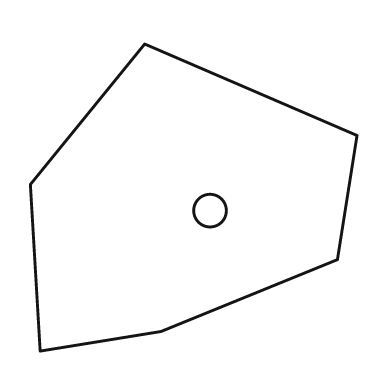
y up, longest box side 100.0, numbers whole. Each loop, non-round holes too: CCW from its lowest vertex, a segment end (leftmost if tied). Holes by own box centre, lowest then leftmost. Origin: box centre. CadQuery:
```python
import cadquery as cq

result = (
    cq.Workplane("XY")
    .moveTo(-47.0, -47.0)
    .lineTo(-10.0, -41.0)
    .lineTo(44.0, -19.0)
    .lineTo(50.0, 19.0)
    .lineTo(-15.0, 47.0)
    .lineTo(-50.0, 4.0)
    .close()
    .moveTo(5.0, -4.0)
    .circle(5.0)
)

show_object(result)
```